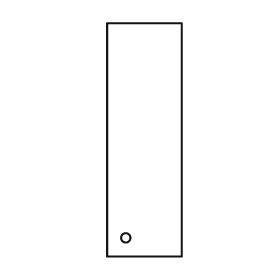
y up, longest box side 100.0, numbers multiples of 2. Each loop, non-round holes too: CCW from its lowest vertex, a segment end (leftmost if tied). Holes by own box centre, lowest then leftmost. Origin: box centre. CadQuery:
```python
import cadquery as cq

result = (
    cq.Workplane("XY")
    .moveTo(-16.0, -50.0)
    .lineTo(16.0, -50.0)
    .lineTo(16.0, 50.0)
    .lineTo(-16.0, 50.0)
    .close()
    .moveTo(-8.0, -42.0)
    .circle(2.0)
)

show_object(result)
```